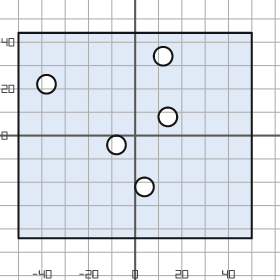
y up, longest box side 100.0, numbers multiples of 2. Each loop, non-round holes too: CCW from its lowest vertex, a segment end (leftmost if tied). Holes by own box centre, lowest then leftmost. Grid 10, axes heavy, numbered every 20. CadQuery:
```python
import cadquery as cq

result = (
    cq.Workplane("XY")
    .moveTo(-50.0, -44.0)
    .lineTo(50.0, -44.0)
    .lineTo(50.0, 44.0)
    .lineTo(-50.0, 44.0)
    .close()
    .moveTo(4.0, -22.0)
    .circle(4.0)
    .moveTo(-8.0, -4.0)
    .circle(4.0)
    .moveTo(14.0, 8.0)
    .circle(4.0)
    .moveTo(-38.0, 22.0)
    .circle(4.0)
    .moveTo(12.0, 34.0)
    .circle(4.0)
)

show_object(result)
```